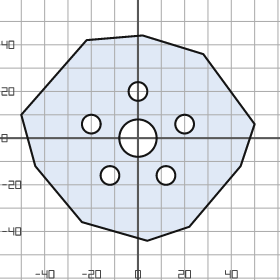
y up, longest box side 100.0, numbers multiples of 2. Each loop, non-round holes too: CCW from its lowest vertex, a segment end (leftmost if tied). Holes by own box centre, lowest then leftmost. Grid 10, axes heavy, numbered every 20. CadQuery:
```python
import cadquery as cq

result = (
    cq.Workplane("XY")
    .moveTo(4.0, -44.0)
    .lineTo(22.0, -38.0)
    .lineTo(44.0, -12.0)
    .lineTo(50.0, 6.0)
    .lineTo(28.0, 36.0)
    .lineTo(2.0, 44.0)
    .lineTo(-22.0, 42.0)
    .lineTo(-50.0, 10.0)
    .lineTo(-44.0, -12.0)
    .lineTo(-24.0, -36.0)
    .close()
    .moveTo(-12.0, -16.0)
    .circle(4.0)
    .moveTo(12.0, -16.0)
    .circle(4.0)
    .moveTo(0.0, 0.0)
    .circle(8.0)
    .moveTo(-20.0, 6.0)
    .circle(4.0)
    .moveTo(20.0, 6.0)
    .circle(4.0)
    .moveTo(0.0, 20.0)
    .circle(4.0)
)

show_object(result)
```